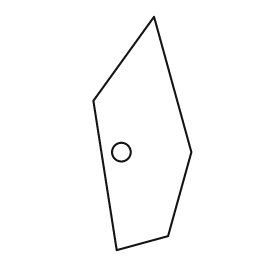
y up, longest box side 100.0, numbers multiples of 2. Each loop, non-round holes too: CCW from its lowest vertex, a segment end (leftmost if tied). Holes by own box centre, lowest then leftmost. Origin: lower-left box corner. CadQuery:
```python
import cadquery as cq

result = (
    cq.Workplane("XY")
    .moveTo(10.0, 0.0)
    .lineTo(32.0, 6.0)
    .lineTo(42.0, 42.0)
    .lineTo(26.0, 100.0)
    .lineTo(0.0, 64.0)
    .close()
    .moveTo(12.0, 42.0)
    .circle(4.0)
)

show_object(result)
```